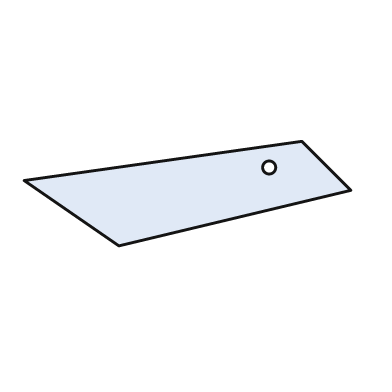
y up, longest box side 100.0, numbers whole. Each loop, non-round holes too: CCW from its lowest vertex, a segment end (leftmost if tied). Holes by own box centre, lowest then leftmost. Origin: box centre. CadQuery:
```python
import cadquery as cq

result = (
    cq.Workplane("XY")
    .moveTo(-21.0, -16.0)
    .lineTo(50.0, 1.0)
    .lineTo(35.0, 16.0)
    .lineTo(-50.0, 4.0)
    .close()
    .moveTo(25.0, 8.0)
    .circle(2.0)
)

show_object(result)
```